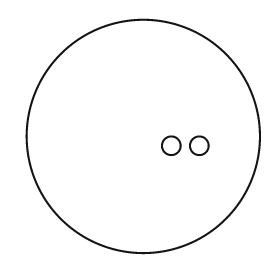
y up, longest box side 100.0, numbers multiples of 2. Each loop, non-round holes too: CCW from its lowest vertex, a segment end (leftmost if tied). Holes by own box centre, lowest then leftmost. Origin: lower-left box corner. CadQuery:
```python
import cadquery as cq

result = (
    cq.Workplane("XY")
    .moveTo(50.0, 50.0)
    .circle(50.0)
    .moveTo(62.0, 46.0)
    .circle(4.0)
    .moveTo(74.0, 46.0)
    .circle(4.0)
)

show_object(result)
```